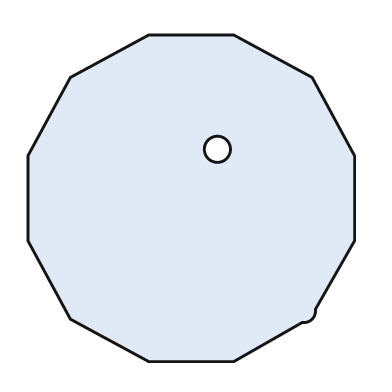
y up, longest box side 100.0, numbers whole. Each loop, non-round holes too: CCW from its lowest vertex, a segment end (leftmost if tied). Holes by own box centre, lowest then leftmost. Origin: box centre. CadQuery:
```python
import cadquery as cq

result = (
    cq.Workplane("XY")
    .moveTo(-13.0, -50.0)
    .lineTo(13.0, -50.0)
    .lineTo(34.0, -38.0)
    .threePointArc((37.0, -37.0), (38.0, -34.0))
    .lineTo(50.0, -13.0)
    .lineTo(50.0, 13.0)
    .lineTo(37.0, 37.0)
    .lineTo(13.0, 50.0)
    .lineTo(-13.0, 50.0)
    .lineTo(-37.0, 37.0)
    .lineTo(-50.0, 13.0)
    .lineTo(-50.0, -13.0)
    .lineTo(-37.0, -37.0)
    .close()
    .moveTo(8.0, 15.0)
    .circle(4.0)
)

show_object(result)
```